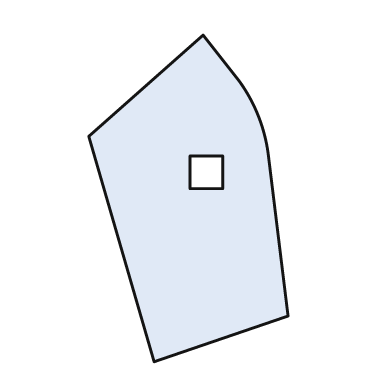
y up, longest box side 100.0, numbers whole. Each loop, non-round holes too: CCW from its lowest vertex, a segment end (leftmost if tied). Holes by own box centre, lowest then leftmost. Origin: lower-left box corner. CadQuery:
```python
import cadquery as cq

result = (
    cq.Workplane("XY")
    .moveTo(20.0, 0.0)
    .lineTo(61.0, 14.0)
    .lineTo(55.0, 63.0)
    .threePointArc((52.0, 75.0), (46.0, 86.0))
    .lineTo(35.0, 100.0)
    .lineTo(0.0, 69.0)
    .close()
    .moveTo(31.0, 53.0)
    .lineTo(41.0, 53.0)
    .lineTo(41.0, 63.0)
    .lineTo(31.0, 63.0)
    .close()
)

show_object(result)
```